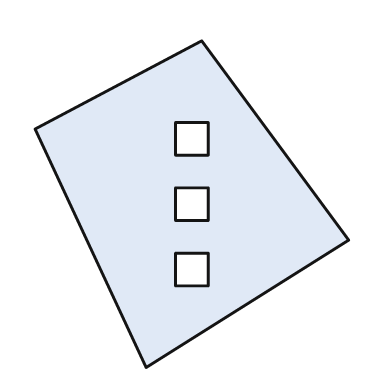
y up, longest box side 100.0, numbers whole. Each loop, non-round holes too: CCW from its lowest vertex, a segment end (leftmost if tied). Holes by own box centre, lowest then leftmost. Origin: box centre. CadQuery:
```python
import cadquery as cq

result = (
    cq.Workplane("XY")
    .moveTo(-14.0, -50.0)
    .lineTo(48.0, -11.0)
    .lineTo(3.0, 50.0)
    .lineTo(-48.0, 23.0)
    .close()
    .moveTo(-5.0, -25.0)
    .lineTo(5.0, -25.0)
    .lineTo(5.0, -15.0)
    .lineTo(-5.0, -15.0)
    .close()
    .moveTo(-5.0, -5.0)
    .lineTo(5.0, -5.0)
    .lineTo(5.0, 5.0)
    .lineTo(-5.0, 5.0)
    .close()
    .moveTo(-5.0, 15.0)
    .lineTo(5.0, 15.0)
    .lineTo(5.0, 25.0)
    .lineTo(-5.0, 25.0)
    .close()
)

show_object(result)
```